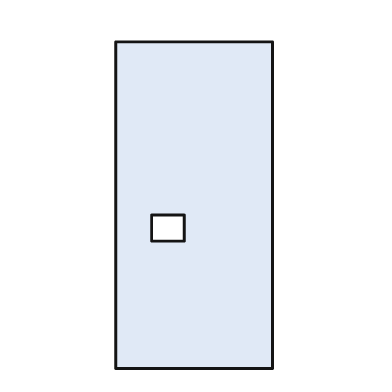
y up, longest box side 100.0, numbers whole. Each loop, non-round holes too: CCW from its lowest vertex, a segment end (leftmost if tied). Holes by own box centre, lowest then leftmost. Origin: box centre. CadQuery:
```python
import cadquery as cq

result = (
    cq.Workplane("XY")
    .moveTo(-24.0, -50.0)
    .lineTo(24.0, -50.0)
    .lineTo(24.0, 50.0)
    .lineTo(-24.0, 50.0)
    .close()
    .moveTo(-13.0, -11.0)
    .lineTo(-3.0, -11.0)
    .lineTo(-3.0, -3.0)
    .lineTo(-13.0, -3.0)
    .close()
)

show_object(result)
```